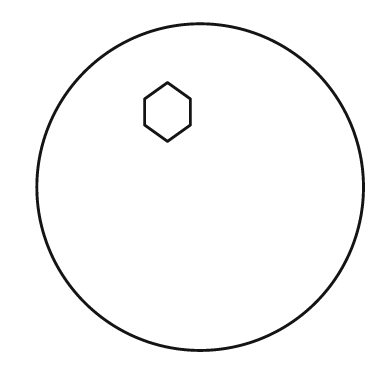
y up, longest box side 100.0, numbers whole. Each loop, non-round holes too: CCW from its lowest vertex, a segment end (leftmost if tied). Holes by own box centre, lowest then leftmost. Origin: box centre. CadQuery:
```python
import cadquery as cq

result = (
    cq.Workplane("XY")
    .moveTo(0.0, 0.0)
    .circle(50.0)
    .moveTo(-10.0, 14.0)
    .lineTo(-3.0, 19.0)
    .lineTo(-3.0, 27.0)
    .lineTo(-10.0, 32.0)
    .lineTo(-17.0, 27.0)
    .lineTo(-17.0, 19.0)
    .close()
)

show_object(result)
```